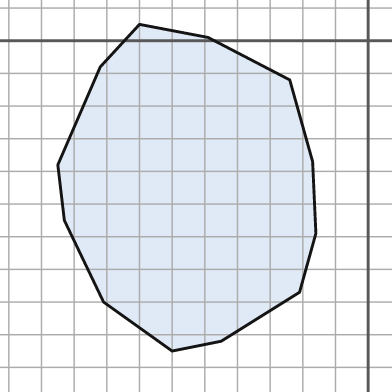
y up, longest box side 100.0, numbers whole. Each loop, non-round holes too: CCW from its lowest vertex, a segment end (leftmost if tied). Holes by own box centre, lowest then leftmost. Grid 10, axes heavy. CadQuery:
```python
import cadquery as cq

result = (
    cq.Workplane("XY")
    .moveTo(-60.0, -95.0)
    .lineTo(-45.0, -92.0)
    .lineTo(-21.0, -77.0)
    .lineTo(-16.0, -59.0)
    .lineTo(-17.0, -37.0)
    .lineTo(-24.0, -12.0)
    .lineTo(-49.0, 1.0)
    .lineTo(-70.0, 5.0)
    .lineTo(-82.0, -8.0)
    .lineTo(-95.0, -38.0)
    .lineTo(-93.0, -55.0)
    .lineTo(-81.0, -80.0)
    .close()
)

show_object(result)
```